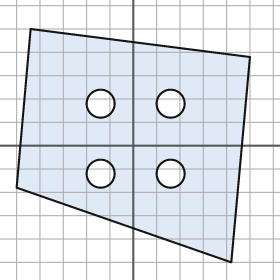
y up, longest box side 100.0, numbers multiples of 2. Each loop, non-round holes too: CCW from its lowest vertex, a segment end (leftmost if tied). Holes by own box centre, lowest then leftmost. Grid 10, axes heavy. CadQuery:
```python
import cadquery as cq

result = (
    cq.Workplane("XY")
    .moveTo(42.0, -50.0)
    .lineTo(50.0, 38.0)
    .lineTo(-44.0, 50.0)
    .lineTo(-50.0, -18.0)
    .close()
    .moveTo(-14.0, -12.0)
    .circle(6.0)
    .moveTo(16.0, -12.0)
    .circle(6.0)
    .moveTo(-14.0, 18.0)
    .circle(6.0)
    .moveTo(16.0, 18.0)
    .circle(6.0)
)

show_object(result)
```